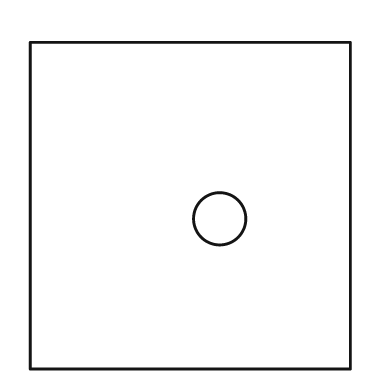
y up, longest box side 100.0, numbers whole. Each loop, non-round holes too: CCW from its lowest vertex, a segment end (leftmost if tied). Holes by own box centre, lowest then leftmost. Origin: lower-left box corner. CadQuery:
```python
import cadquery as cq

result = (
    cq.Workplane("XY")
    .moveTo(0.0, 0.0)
    .lineTo(98.0, 0.0)
    .lineTo(98.0, 100.0)
    .lineTo(0.0, 100.0)
    .close()
    .moveTo(58.0, 46.0)
    .circle(8.0)
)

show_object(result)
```